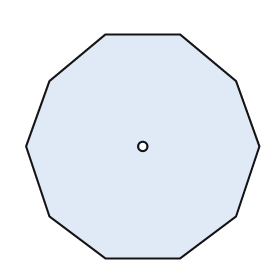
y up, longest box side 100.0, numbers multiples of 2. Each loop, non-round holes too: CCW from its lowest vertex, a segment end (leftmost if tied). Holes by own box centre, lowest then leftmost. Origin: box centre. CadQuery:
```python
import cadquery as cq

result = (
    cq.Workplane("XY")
    .moveTo(-16.0, -48.0)
    .lineTo(16.0, -48.0)
    .lineTo(40.0, -30.0)
    .lineTo(50.0, 0.0)
    .lineTo(40.0, 28.0)
    .lineTo(16.0, 48.0)
    .lineTo(-16.0, 48.0)
    .lineTo(-40.0, 28.0)
    .lineTo(-50.0, 0.0)
    .lineTo(-40.0, -30.0)
    .close()
    .moveTo(0.0, 0.0)
    .circle(2.0)
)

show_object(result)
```